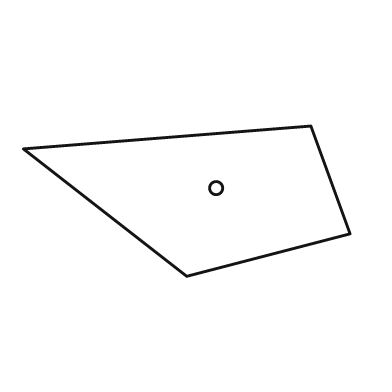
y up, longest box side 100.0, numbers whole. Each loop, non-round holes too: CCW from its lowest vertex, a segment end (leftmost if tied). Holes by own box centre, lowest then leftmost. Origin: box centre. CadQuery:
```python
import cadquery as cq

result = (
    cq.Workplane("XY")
    .moveTo(0.0, -23.0)
    .lineTo(50.0, -10.0)
    .lineTo(38.0, 23.0)
    .lineTo(-50.0, 16.0)
    .close()
    .moveTo(9.0, 4.0)
    .circle(2.0)
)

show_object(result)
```